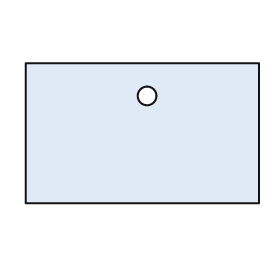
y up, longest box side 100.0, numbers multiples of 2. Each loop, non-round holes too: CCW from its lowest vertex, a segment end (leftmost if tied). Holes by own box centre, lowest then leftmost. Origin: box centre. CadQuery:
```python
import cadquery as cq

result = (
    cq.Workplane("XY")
    .moveTo(-50.0, -30.0)
    .lineTo(50.0, -30.0)
    .lineTo(50.0, 30.0)
    .lineTo(-50.0, 30.0)
    .close()
    .moveTo(2.0, 16.0)
    .circle(4.0)
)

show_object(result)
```